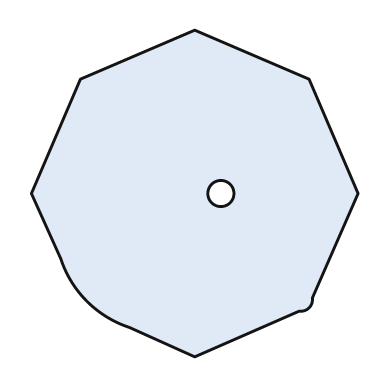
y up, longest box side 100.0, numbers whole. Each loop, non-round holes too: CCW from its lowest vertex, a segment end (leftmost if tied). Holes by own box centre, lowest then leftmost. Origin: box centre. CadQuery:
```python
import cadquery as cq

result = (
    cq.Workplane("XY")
    .moveTo(0.0, -50.0)
    .lineTo(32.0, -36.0)
    .threePointArc((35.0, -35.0), (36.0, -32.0))
    .lineTo(50.0, 0.0)
    .lineTo(35.0, 35.0)
    .lineTo(0.0, 50.0)
    .lineTo(-35.0, 35.0)
    .lineTo(-50.0, 0.0)
    .lineTo(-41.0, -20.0)
    .threePointArc((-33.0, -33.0), (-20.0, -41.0))
    .close()
    .moveTo(8.0, 0.0)
    .circle(4.0)
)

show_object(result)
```